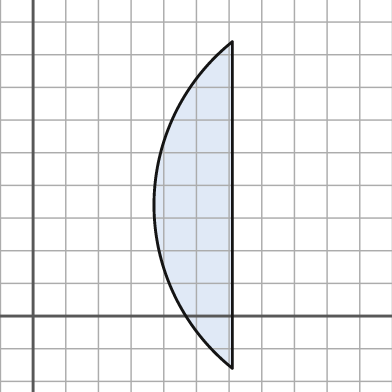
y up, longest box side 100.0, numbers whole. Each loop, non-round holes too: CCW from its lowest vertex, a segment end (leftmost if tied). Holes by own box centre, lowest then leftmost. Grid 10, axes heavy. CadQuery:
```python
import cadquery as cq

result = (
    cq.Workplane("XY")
    .moveTo(61.0, -16.0)
    .lineTo(61.0, 84.0)
    .threePointArc((37.0, 34.0), (61.0, -16.0))
    .close()
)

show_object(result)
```